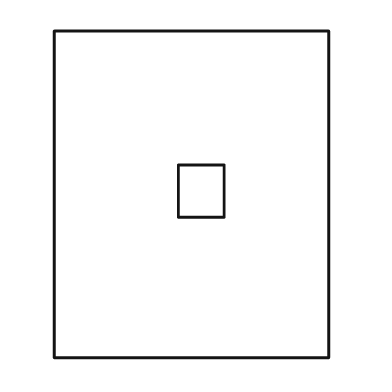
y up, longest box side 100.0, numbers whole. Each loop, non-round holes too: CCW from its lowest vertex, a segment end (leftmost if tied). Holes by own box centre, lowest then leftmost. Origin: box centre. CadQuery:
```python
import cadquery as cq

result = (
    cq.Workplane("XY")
    .moveTo(-42.0, -50.0)
    .lineTo(42.0, -50.0)
    .lineTo(42.0, 50.0)
    .lineTo(-42.0, 50.0)
    .close()
    .moveTo(-4.0, -7.0)
    .lineTo(10.0, -7.0)
    .lineTo(10.0, 9.0)
    .lineTo(-4.0, 9.0)
    .close()
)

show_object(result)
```